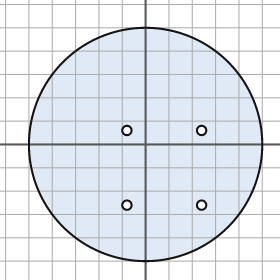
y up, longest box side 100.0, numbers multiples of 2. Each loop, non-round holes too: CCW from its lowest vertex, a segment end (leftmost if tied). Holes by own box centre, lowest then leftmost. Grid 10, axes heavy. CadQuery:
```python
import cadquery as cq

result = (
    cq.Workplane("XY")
    .moveTo(0.0, 0.0)
    .circle(50.0)
    .moveTo(-8.0, -26.0)
    .circle(2.0)
    .moveTo(24.0, -26.0)
    .circle(2.0)
    .moveTo(-8.0, 6.0)
    .circle(2.0)
    .moveTo(24.0, 6.0)
    .circle(2.0)
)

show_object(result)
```